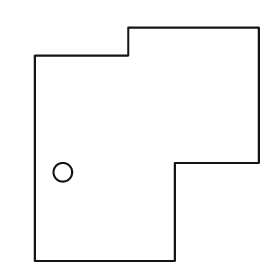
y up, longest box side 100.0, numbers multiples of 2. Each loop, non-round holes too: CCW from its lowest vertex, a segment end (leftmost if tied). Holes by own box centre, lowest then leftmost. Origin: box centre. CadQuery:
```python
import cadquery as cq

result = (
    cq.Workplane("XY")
    .moveTo(-48.0, -50.0)
    .lineTo(12.0, -50.0)
    .lineTo(12.0, -8.0)
    .lineTo(48.0, -8.0)
    .lineTo(48.0, 50.0)
    .lineTo(-8.0, 50.0)
    .lineTo(-8.0, 38.0)
    .lineTo(-48.0, 38.0)
    .close()
    .moveTo(-36.0, -12.0)
    .circle(4.0)
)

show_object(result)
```